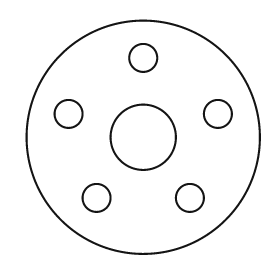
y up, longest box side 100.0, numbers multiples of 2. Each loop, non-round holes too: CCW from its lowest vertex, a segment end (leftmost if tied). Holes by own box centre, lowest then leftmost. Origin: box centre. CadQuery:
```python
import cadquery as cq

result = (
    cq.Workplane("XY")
    .moveTo(0.0, 0.0)
    .circle(50.0)
    .moveTo(-20.0, -26.0)
    .circle(6.0)
    .moveTo(20.0, -26.0)
    .circle(6.0)
    .moveTo(0.0, 0.0)
    .circle(14.0)
    .moveTo(-32.0, 10.0)
    .circle(6.0)
    .moveTo(32.0, 10.0)
    .circle(6.0)
    .moveTo(0.0, 34.0)
    .circle(6.0)
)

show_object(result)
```